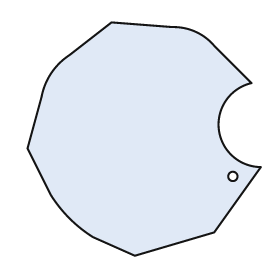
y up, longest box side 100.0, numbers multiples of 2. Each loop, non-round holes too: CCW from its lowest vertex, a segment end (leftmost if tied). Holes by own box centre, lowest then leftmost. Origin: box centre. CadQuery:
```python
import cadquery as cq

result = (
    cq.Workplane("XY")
    .moveTo(-4.0, -50.0)
    .lineTo(30.0, -40.0)
    .lineTo(50.0, -12.0)
    .threePointArc((32.0, 4.0), (46.0, 24.0))
    .lineTo(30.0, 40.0)
    .threePointArc((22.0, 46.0), (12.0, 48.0))
    .lineTo(-14.0, 50.0)
    .lineTo(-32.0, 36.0)
    .threePointArc((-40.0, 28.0), (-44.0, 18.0))
    .lineTo(-50.0, -4.0)
    .lineTo(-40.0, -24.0)
    .threePointArc((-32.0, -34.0), (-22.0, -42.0))
    .close()
    .moveTo(38.0, -16.0)
    .circle(2.0)
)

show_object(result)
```